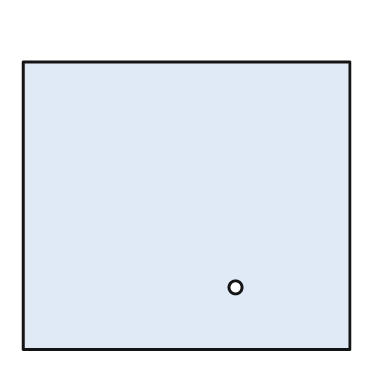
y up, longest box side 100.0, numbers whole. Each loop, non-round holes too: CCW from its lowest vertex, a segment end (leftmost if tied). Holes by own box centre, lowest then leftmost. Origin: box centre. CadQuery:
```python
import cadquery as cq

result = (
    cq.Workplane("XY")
    .moveTo(-50.0, -44.0)
    .lineTo(50.0, -44.0)
    .lineTo(50.0, 44.0)
    .lineTo(-50.0, 44.0)
    .close()
    .moveTo(15.0, -25.0)
    .circle(2.0)
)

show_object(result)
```